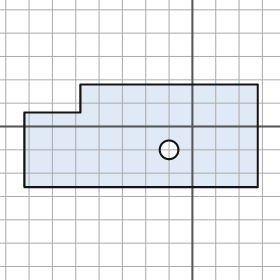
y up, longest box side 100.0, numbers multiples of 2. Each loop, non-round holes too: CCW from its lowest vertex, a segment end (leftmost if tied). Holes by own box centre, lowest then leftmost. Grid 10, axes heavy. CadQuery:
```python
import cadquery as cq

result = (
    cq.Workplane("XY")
    .moveTo(-72.0, -26.0)
    .lineTo(28.0, -26.0)
    .lineTo(28.0, 18.0)
    .lineTo(-48.0, 18.0)
    .lineTo(-48.0, 6.0)
    .lineTo(-72.0, 6.0)
    .close()
    .moveTo(-10.0, -10.0)
    .circle(4.0)
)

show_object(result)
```